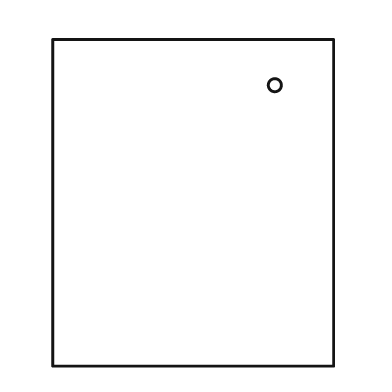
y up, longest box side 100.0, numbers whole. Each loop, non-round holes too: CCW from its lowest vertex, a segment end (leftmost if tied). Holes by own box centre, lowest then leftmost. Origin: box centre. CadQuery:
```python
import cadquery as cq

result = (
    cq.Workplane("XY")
    .moveTo(-43.0, -50.0)
    .lineTo(43.0, -50.0)
    .lineTo(43.0, 50.0)
    .lineTo(-43.0, 50.0)
    .close()
    .moveTo(25.0, 36.0)
    .circle(2.0)
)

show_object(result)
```